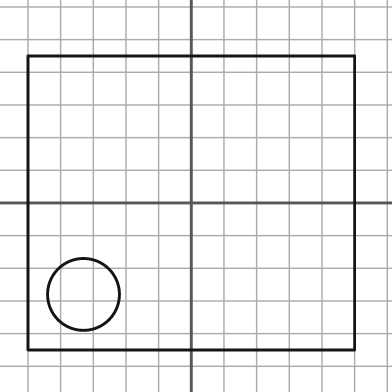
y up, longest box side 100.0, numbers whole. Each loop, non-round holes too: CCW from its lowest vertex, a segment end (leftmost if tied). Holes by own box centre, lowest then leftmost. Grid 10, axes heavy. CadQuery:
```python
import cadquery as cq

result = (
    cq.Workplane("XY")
    .moveTo(-50.0, -45.0)
    .lineTo(50.0, -45.0)
    .lineTo(50.0, 45.0)
    .lineTo(-50.0, 45.0)
    .close()
    .moveTo(-33.0, -28.0)
    .circle(11.0)
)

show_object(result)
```